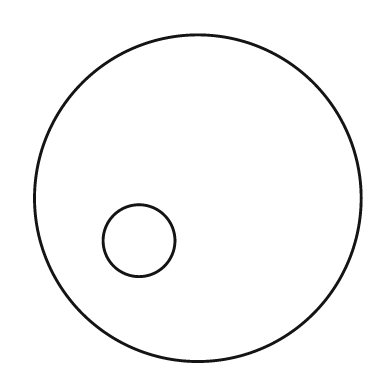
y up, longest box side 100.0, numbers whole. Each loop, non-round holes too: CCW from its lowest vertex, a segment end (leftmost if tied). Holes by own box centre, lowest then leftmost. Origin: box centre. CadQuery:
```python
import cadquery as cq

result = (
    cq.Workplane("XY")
    .moveTo(0.0, 0.0)
    .circle(50.0)
    .moveTo(-18.0, -13.0)
    .circle(11.0)
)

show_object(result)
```